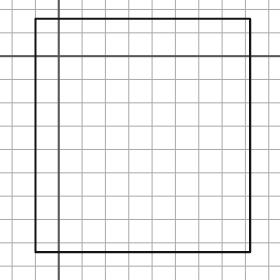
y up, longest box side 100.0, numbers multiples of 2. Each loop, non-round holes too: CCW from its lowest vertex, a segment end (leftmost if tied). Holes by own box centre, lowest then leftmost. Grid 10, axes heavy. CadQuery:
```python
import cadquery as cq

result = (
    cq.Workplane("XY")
    .moveTo(-10.0, -84.0)
    .lineTo(82.0, -84.0)
    .lineTo(82.0, 16.0)
    .lineTo(-10.0, 16.0)
    .close()
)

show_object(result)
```